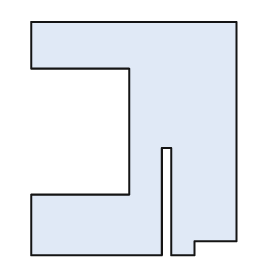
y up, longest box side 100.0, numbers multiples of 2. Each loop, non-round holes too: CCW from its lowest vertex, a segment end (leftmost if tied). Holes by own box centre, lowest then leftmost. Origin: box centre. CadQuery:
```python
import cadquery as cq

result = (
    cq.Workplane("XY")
    .moveTo(-44.0, -50.0)
    .lineTo(12.0, -50.0)
    .lineTo(12.0, -4.0)
    .lineTo(16.0, -4.0)
    .lineTo(16.0, -50.0)
    .lineTo(26.0, -50.0)
    .lineTo(26.0, -44.0)
    .lineTo(44.0, -44.0)
    .lineTo(44.0, 50.0)
    .lineTo(-44.0, 50.0)
    .lineTo(-44.0, 30.0)
    .lineTo(-2.0, 30.0)
    .lineTo(-2.0, -24.0)
    .lineTo(-44.0, -24.0)
    .close()
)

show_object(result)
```